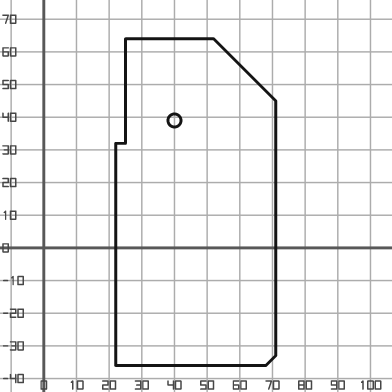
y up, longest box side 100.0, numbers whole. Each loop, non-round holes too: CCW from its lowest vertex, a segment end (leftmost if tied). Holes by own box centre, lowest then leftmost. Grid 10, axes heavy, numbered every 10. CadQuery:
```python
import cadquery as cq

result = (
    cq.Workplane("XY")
    .moveTo(22.0, -36.0)
    .lineTo(68.0, -36.0)
    .lineTo(71.0, -33.0)
    .lineTo(71.0, 45.0)
    .lineTo(52.0, 64.0)
    .lineTo(25.0, 64.0)
    .lineTo(25.0, 32.0)
    .lineTo(22.0, 32.0)
    .close()
    .moveTo(40.0, 39.0)
    .circle(2.0)
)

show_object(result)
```